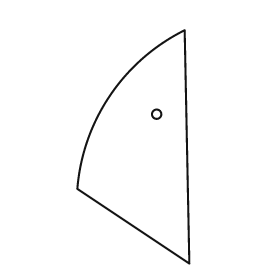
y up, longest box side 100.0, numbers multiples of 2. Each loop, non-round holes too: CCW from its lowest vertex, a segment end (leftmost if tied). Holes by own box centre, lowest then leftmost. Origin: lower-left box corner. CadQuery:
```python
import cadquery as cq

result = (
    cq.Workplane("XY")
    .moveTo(48.0, 0.0)
    .lineTo(46.0, 100.0)
    .threePointArc((14.0, 72.0), (0.0, 32.0))
    .close()
    .moveTo(34.0, 64.0)
    .circle(2.0)
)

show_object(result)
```